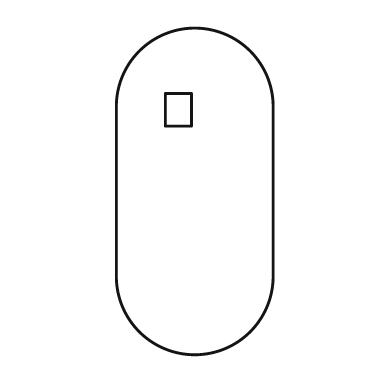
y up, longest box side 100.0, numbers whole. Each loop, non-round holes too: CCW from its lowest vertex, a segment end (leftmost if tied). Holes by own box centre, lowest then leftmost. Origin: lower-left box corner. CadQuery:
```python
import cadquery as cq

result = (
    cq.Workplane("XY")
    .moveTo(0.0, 24.0)
    .threePointArc((24.0, 0.0), (48.0, 24.0))
    .lineTo(48.0, 76.0)
    .threePointArc((24.0, 100.0), (0.0, 76.0))
    .close()
    .moveTo(15.0, 70.0)
    .lineTo(23.0, 70.0)
    .lineTo(23.0, 80.0)
    .lineTo(15.0, 80.0)
    .close()
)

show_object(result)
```